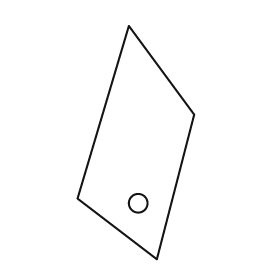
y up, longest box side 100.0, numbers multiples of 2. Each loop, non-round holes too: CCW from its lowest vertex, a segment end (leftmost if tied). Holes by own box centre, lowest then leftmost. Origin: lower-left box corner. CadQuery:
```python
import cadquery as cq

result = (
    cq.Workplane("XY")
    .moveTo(34.0, 0.0)
    .lineTo(50.0, 62.0)
    .lineTo(22.0, 100.0)
    .lineTo(0.0, 26.0)
    .close()
    .moveTo(26.0, 24.0)
    .circle(4.0)
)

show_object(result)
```